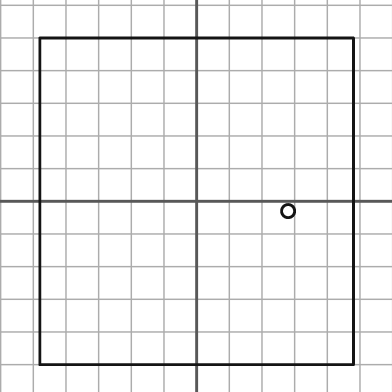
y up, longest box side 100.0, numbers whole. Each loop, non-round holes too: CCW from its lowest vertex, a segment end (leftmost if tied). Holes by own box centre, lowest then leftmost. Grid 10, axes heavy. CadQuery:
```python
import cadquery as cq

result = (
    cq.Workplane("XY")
    .moveTo(-48.0, -50.0)
    .lineTo(48.0, -50.0)
    .lineTo(48.0, 50.0)
    .lineTo(-48.0, 50.0)
    .close()
    .moveTo(28.0, -3.0)
    .circle(2.0)
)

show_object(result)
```